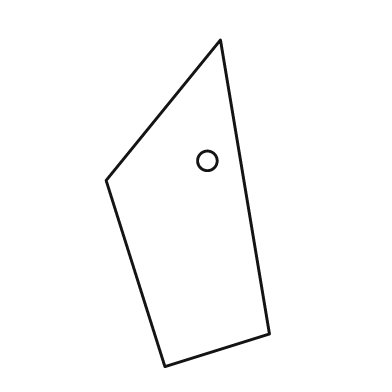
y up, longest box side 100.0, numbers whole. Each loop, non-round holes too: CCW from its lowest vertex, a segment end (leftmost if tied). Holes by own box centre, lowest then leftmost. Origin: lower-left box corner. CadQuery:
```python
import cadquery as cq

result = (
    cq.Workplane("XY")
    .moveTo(18.0, 0.0)
    .lineTo(50.0, 10.0)
    .lineTo(35.0, 100.0)
    .lineTo(0.0, 57.0)
    .close()
    .moveTo(31.0, 63.0)
    .circle(3.0)
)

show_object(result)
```